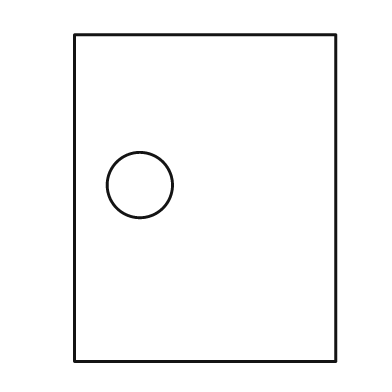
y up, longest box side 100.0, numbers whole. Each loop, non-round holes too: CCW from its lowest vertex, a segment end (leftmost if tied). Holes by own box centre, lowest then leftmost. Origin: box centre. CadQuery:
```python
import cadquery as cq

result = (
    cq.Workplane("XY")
    .moveTo(-40.0, -50.0)
    .lineTo(40.0, -50.0)
    .lineTo(40.0, 50.0)
    .lineTo(-40.0, 50.0)
    .close()
    .moveTo(-20.0, 4.0)
    .circle(10.0)
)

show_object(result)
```